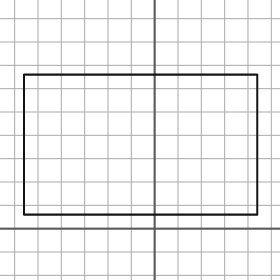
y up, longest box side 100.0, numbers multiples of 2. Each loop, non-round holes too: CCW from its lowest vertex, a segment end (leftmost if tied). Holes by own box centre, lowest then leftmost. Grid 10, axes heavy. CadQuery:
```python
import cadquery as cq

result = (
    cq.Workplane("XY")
    .moveTo(-56.0, 6.0)
    .lineTo(44.0, 6.0)
    .lineTo(44.0, 66.0)
    .lineTo(-56.0, 66.0)
    .close()
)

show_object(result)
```